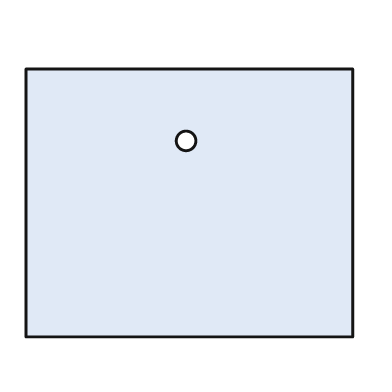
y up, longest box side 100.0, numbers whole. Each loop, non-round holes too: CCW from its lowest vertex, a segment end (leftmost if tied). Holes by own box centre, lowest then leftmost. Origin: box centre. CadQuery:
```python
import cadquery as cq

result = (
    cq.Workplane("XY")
    .moveTo(-50.0, -41.0)
    .lineTo(50.0, -41.0)
    .lineTo(50.0, 41.0)
    .lineTo(-50.0, 41.0)
    .close()
    .moveTo(-1.0, 19.0)
    .circle(3.0)
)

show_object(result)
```